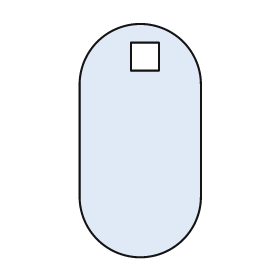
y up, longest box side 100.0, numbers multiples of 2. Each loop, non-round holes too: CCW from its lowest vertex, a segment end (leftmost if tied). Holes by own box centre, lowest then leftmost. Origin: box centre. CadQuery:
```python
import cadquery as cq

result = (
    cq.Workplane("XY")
    .moveTo(-26.0, -24.0)
    .threePointArc((0.0, -50.0), (26.0, -24.0))
    .lineTo(26.0, 24.0)
    .threePointArc((0.0, 50.0), (-26.0, 24.0))
    .close()
    .moveTo(-4.0, 30.0)
    .lineTo(8.0, 30.0)
    .lineTo(8.0, 42.0)
    .lineTo(-4.0, 42.0)
    .close()
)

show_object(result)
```